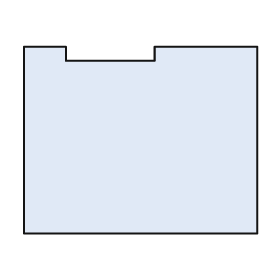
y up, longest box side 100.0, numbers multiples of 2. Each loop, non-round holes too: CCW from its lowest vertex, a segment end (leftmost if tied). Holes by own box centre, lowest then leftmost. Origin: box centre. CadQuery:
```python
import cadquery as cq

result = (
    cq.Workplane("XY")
    .moveTo(-50.0, -40.0)
    .lineTo(50.0, -40.0)
    .lineTo(50.0, 40.0)
    .lineTo(6.0, 40.0)
    .lineTo(6.0, 34.0)
    .lineTo(-32.0, 34.0)
    .lineTo(-32.0, 40.0)
    .lineTo(-50.0, 40.0)
    .close()
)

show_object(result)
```